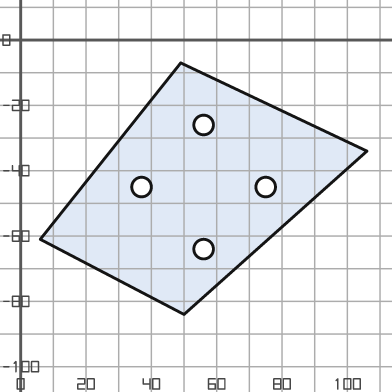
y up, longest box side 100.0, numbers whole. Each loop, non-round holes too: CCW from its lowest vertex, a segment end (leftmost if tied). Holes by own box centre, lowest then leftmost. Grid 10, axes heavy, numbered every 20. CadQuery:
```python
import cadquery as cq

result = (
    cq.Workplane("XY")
    .moveTo(50.0, -84.0)
    .lineTo(106.0, -34.0)
    .lineTo(49.0, -7.0)
    .lineTo(6.0, -61.0)
    .close()
    .moveTo(56.0, -64.0)
    .circle(3.0)
    .moveTo(37.0, -45.0)
    .circle(3.0)
    .moveTo(75.0, -45.0)
    .circle(3.0)
    .moveTo(56.0, -26.0)
    .circle(3.0)
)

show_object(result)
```